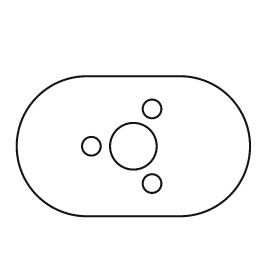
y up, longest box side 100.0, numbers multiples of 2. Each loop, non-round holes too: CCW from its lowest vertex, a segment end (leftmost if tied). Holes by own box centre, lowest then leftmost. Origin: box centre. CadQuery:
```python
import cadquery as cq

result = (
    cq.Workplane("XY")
    .moveTo(-20.0, -30.0)
    .lineTo(20.0, -30.0)
    .threePointArc((50.0, 0.0), (20.0, 30.0))
    .lineTo(-20.0, 30.0)
    .threePointArc((-50.0, 0.0), (-20.0, -30.0))
    .close()
    .moveTo(8.0, -16.0)
    .circle(4.0)
    .moveTo(-18.0, 0.0)
    .circle(4.0)
    .moveTo(0.0, 0.0)
    .circle(10.0)
    .moveTo(8.0, 16.0)
    .circle(4.0)
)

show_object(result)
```